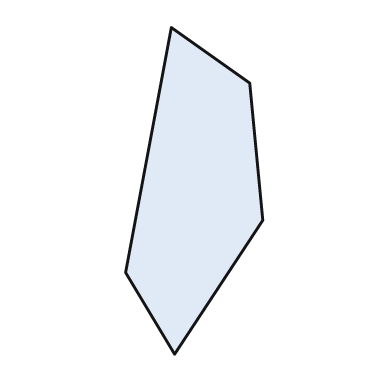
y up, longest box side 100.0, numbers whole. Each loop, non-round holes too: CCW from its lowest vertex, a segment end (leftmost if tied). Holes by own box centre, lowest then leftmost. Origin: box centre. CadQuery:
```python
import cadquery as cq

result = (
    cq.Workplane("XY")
    .moveTo(-6.0, -50.0)
    .lineTo(21.0, -9.0)
    .lineTo(17.0, 33.0)
    .lineTo(-7.0, 50.0)
    .lineTo(-21.0, -25.0)
    .close()
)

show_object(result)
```